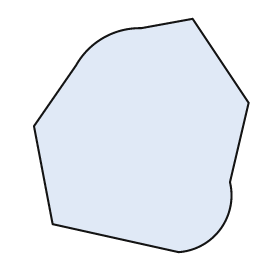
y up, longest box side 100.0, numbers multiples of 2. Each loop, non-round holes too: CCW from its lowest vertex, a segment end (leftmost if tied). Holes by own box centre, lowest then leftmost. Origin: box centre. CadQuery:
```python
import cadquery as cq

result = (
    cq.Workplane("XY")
    .moveTo(16.0, -50.0)
    .threePointArc((34.0, -40.0), (38.0, -20.0))
    .lineTo(46.0, 14.0)
    .lineTo(22.0, 50.0)
    .lineTo(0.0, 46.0)
    .threePointArc((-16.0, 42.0), (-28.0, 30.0))
    .lineTo(-46.0, 4.0)
    .lineTo(-38.0, -38.0)
    .close()
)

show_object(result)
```